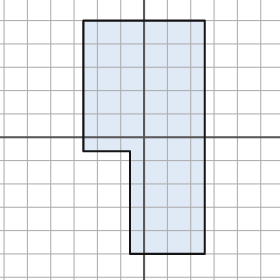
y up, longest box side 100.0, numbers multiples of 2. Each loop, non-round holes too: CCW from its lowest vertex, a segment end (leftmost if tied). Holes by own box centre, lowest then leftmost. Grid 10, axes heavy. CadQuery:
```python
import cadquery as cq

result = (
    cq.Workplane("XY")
    .moveTo(-6.0, -50.0)
    .lineTo(26.0, -50.0)
    .lineTo(26.0, 50.0)
    .lineTo(-26.0, 50.0)
    .lineTo(-26.0, -6.0)
    .lineTo(-6.0, -6.0)
    .close()
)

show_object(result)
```